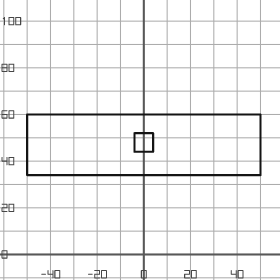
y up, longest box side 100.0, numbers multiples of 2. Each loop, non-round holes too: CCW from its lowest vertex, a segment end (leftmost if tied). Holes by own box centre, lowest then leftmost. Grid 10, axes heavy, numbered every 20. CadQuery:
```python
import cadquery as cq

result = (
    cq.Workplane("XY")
    .moveTo(-50.0, 34.0)
    .lineTo(50.0, 34.0)
    .lineTo(50.0, 60.0)
    .lineTo(-50.0, 60.0)
    .close()
    .moveTo(-4.0, 44.0)
    .lineTo(4.0, 44.0)
    .lineTo(4.0, 52.0)
    .lineTo(-4.0, 52.0)
    .close()
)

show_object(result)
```